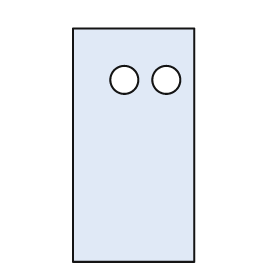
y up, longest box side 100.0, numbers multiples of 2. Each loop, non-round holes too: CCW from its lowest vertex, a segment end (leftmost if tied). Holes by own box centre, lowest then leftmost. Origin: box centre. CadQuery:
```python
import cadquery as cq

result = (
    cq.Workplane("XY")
    .moveTo(-26.0, -50.0)
    .lineTo(26.0, -50.0)
    .lineTo(26.0, 50.0)
    .lineTo(-26.0, 50.0)
    .close()
    .moveTo(-4.0, 28.0)
    .circle(6.0)
    .moveTo(14.0, 28.0)
    .circle(6.0)
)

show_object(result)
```